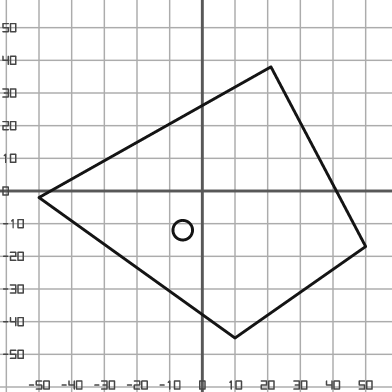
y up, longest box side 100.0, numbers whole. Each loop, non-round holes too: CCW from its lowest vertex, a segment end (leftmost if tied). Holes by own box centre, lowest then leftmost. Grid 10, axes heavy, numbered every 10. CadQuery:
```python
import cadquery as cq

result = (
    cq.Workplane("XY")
    .moveTo(10.0, -45.0)
    .lineTo(50.0, -17.0)
    .lineTo(21.0, 38.0)
    .lineTo(-50.0, -2.0)
    .close()
    .moveTo(-6.0, -12.0)
    .circle(3.0)
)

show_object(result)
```